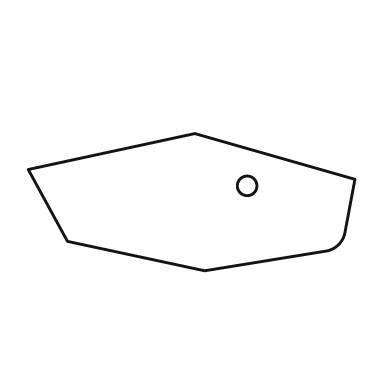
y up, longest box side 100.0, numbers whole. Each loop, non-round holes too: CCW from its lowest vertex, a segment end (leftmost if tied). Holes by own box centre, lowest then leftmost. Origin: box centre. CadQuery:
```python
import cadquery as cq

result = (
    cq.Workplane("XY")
    .moveTo(4.0, -21.0)
    .lineTo(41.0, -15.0)
    .threePointArc((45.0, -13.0), (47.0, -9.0))
    .lineTo(50.0, 7.0)
    .lineTo(1.0, 21.0)
    .lineTo(-50.0, 10.0)
    .lineTo(-38.0, -12.0)
    .close()
    .moveTo(17.0, 5.0)
    .circle(3.0)
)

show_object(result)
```